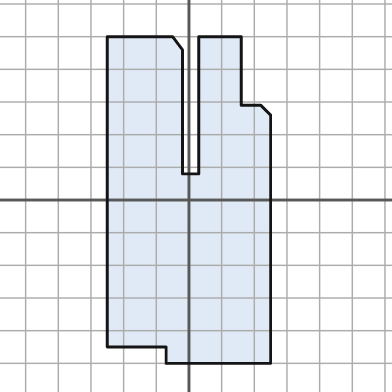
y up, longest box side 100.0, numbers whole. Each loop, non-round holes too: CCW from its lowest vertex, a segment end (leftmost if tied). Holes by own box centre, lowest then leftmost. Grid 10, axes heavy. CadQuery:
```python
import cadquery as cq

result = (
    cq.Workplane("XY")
    .moveTo(-7.0, -50.0)
    .lineTo(25.0, -50.0)
    .lineTo(25.0, 26.0)
    .lineTo(22.0, 29.0)
    .lineTo(16.0, 29.0)
    .lineTo(16.0, 50.0)
    .lineTo(3.0, 50.0)
    .lineTo(3.0, 8.0)
    .lineTo(-2.0, 8.0)
    .lineTo(-2.0, 46.0)
    .lineTo(-5.0, 50.0)
    .lineTo(-25.0, 50.0)
    .lineTo(-25.0, -45.0)
    .lineTo(-7.0, -45.0)
    .close()
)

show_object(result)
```